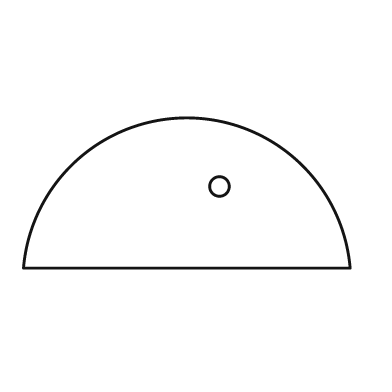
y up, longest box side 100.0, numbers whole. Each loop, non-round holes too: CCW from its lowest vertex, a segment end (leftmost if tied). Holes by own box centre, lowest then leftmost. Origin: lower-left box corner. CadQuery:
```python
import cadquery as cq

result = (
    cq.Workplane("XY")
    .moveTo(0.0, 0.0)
    .lineTo(100.0, 0.0)
    .threePointArc((50.0, 46.0), (0.0, 0.0))
    .close()
    .moveTo(60.0, 25.0)
    .circle(3.0)
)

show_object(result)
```